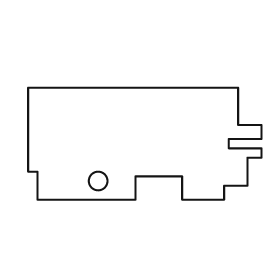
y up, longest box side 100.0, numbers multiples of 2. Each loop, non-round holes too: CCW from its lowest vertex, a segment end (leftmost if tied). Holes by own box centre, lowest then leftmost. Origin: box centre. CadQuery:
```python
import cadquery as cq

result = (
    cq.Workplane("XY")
    .moveTo(-46.0, -24.0)
    .lineTo(-4.0, -24.0)
    .lineTo(-4.0, -14.0)
    .lineTo(16.0, -14.0)
    .lineTo(16.0, -24.0)
    .lineTo(34.0, -24.0)
    .lineTo(34.0, -18.0)
    .lineTo(44.0, -18.0)
    .lineTo(44.0, -6.0)
    .lineTo(50.0, -6.0)
    .lineTo(50.0, -2.0)
    .lineTo(36.0, -2.0)
    .lineTo(36.0, 2.0)
    .lineTo(50.0, 2.0)
    .lineTo(50.0, 8.0)
    .lineTo(40.0, 8.0)
    .lineTo(40.0, 24.0)
    .lineTo(-50.0, 24.0)
    .lineTo(-50.0, -12.0)
    .lineTo(-46.0, -12.0)
    .close()
    .moveTo(-20.0, -16.0)
    .circle(4.0)
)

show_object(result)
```